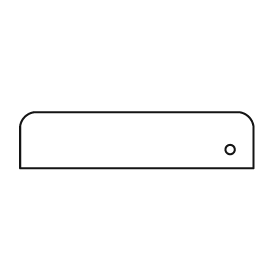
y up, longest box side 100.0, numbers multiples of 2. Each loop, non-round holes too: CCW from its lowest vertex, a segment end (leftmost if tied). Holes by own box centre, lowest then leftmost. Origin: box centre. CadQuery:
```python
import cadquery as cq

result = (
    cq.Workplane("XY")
    .moveTo(-50.0, -12.0)
    .lineTo(50.0, -12.0)
    .lineTo(50.0, 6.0)
    .threePointArc((48.0, 10.0), (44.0, 12.0))
    .lineTo(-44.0, 12.0)
    .threePointArc((-48.0, 10.0), (-50.0, 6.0))
    .close()
    .moveTo(40.0, -4.0)
    .circle(2.0)
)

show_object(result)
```